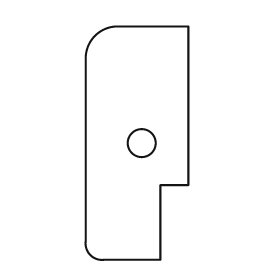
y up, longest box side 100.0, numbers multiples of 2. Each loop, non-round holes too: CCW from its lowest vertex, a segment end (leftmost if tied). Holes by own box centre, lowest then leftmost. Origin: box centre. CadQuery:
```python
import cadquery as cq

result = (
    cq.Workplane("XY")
    .moveTo(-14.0, -50.0)
    .lineTo(10.0, -50.0)
    .lineTo(10.0, -18.0)
    .lineTo(22.0, -18.0)
    .lineTo(22.0, 50.0)
    .lineTo(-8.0, 50.0)
    .threePointArc((-18.0, 46.0), (-22.0, 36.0))
    .lineTo(-22.0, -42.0)
    .threePointArc((-20.0, -48.0), (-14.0, -50.0))
    .close()
    .moveTo(2.0, 0.0)
    .circle(6.0)
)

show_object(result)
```